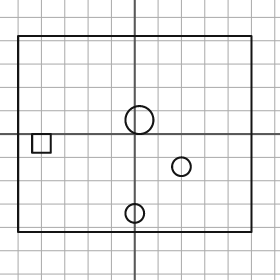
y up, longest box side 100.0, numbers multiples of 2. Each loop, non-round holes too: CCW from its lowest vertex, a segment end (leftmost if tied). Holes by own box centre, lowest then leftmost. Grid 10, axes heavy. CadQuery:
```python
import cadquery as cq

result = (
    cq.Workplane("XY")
    .moveTo(-50.0, -42.0)
    .lineTo(50.0, -42.0)
    .lineTo(50.0, 42.0)
    .lineTo(-50.0, 42.0)
    .close()
    .moveTo(0.0, -34.0)
    .circle(4.0)
    .moveTo(20.0, -14.0)
    .circle(4.0)
    .moveTo(-44.0, -8.0)
    .lineTo(-36.0, -8.0)
    .lineTo(-36.0, 0.0)
    .lineTo(-44.0, 0.0)
    .close()
    .moveTo(2.0, 6.0)
    .circle(6.0)
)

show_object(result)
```